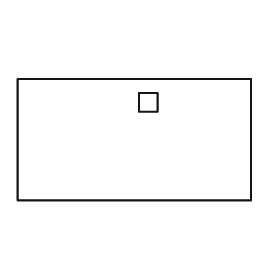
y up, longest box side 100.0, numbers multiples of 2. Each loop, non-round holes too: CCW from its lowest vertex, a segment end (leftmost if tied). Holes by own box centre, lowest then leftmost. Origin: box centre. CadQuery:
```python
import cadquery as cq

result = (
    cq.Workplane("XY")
    .moveTo(-50.0, -26.0)
    .lineTo(50.0, -26.0)
    .lineTo(50.0, 26.0)
    .lineTo(-50.0, 26.0)
    .close()
    .moveTo(2.0, 12.0)
    .lineTo(10.0, 12.0)
    .lineTo(10.0, 20.0)
    .lineTo(2.0, 20.0)
    .close()
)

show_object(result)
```